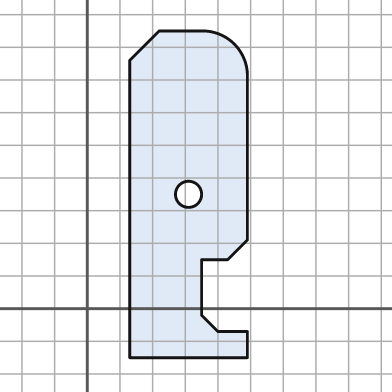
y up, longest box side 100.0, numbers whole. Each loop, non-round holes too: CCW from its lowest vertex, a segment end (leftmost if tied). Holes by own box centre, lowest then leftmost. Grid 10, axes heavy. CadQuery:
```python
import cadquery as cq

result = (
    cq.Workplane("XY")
    .moveTo(13.0, -15.0)
    .lineTo(49.0, -15.0)
    .lineTo(49.0, -7.0)
    .lineTo(40.0, -7.0)
    .lineTo(35.0, -2.0)
    .lineTo(35.0, 15.0)
    .lineTo(43.0, 15.0)
    .lineTo(49.0, 21.0)
    .lineTo(49.0, 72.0)
    .threePointArc((45.0, 81.0), (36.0, 85.0))
    .lineTo(22.0, 85.0)
    .lineTo(13.0, 76.0)
    .close()
    .moveTo(31.0, 35.0)
    .circle(4.0)
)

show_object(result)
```